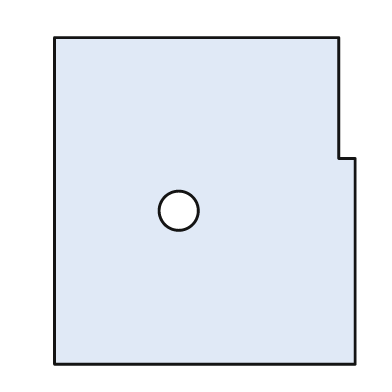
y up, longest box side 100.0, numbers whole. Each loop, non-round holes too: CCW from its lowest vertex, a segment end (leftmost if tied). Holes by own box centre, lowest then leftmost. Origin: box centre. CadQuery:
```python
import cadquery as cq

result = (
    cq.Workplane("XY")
    .moveTo(-46.0, -50.0)
    .lineTo(46.0, -50.0)
    .lineTo(46.0, 13.0)
    .lineTo(41.0, 13.0)
    .lineTo(41.0, 50.0)
    .lineTo(-46.0, 50.0)
    .close()
    .moveTo(-8.0, -3.0)
    .circle(6.0)
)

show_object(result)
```